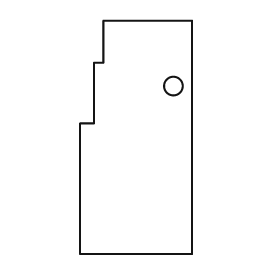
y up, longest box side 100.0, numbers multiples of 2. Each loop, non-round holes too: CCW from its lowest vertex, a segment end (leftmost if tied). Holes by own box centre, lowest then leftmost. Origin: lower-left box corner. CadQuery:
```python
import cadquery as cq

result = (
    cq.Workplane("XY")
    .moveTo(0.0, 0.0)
    .lineTo(48.0, 0.0)
    .lineTo(48.0, 100.0)
    .lineTo(10.0, 100.0)
    .lineTo(10.0, 82.0)
    .lineTo(6.0, 82.0)
    .lineTo(6.0, 56.0)
    .lineTo(0.0, 56.0)
    .close()
    .moveTo(40.0, 72.0)
    .circle(4.0)
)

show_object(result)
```